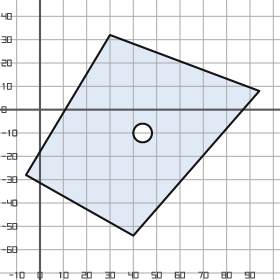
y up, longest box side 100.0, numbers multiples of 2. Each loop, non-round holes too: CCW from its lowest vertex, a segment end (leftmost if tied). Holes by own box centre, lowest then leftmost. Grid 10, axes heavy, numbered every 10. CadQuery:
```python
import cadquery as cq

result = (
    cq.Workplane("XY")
    .moveTo(40.0, -54.0)
    .lineTo(94.0, 8.0)
    .lineTo(30.0, 32.0)
    .lineTo(-6.0, -28.0)
    .close()
    .moveTo(44.0, -10.0)
    .circle(4.0)
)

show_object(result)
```